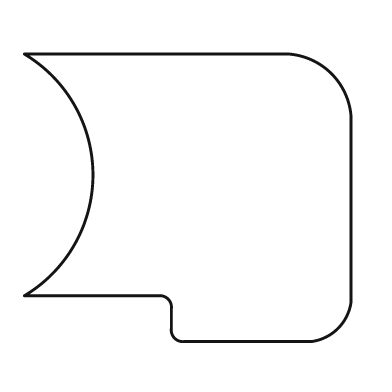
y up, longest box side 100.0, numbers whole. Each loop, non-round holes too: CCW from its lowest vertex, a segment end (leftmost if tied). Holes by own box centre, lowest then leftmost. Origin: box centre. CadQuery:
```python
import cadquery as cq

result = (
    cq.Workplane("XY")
    .moveTo(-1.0, -44.0)
    .lineTo(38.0, -44.0)
    .threePointArc((46.0, -40.0), (50.0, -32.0))
    .lineTo(50.0, 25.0)
    .threePointArc((44.0, 38.0), (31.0, 44.0))
    .lineTo(-50.0, 44.0)
    .threePointArc((-29.0, 7.0), (-50.0, -30.0))
    .lineTo(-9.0, -30.0)
    .threePointArc((-6.0, -31.0), (-5.0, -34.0))
    .lineTo(-5.0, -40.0)
    .threePointArc((-4.0, -43.0), (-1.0, -44.0))
    .close()
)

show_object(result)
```